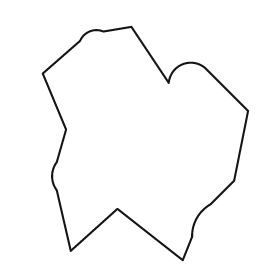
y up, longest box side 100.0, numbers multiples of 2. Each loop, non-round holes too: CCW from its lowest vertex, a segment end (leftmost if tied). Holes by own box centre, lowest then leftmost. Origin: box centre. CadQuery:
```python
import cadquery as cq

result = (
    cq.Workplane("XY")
    .moveTo(16.0, -50.0)
    .lineTo(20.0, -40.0)
    .threePointArc((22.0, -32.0), (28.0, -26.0))
    .lineTo(38.0, -16.0)
    .lineTo(44.0, 14.0)
    .lineTo(26.0, 32.0)
    .threePointArc((16.0, 34.0), (10.0, 26.0))
    .lineTo(-6.0, 50.0)
    .lineTo(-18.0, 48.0)
    .threePointArc((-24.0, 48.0), (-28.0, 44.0))
    .lineTo(-44.0, 30.0)
    .lineTo(-34.0, 6.0)
    .lineTo(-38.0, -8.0)
    .threePointArc((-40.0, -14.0), (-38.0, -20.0))
    .lineTo(-32.0, -46.0)
    .lineTo(-12.0, -28.0)
    .close()
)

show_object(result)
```